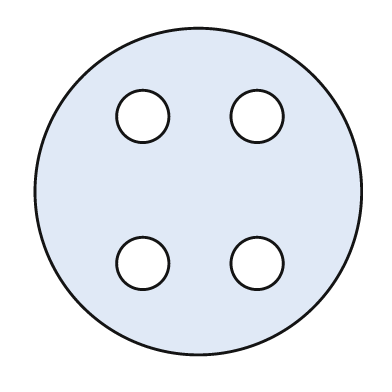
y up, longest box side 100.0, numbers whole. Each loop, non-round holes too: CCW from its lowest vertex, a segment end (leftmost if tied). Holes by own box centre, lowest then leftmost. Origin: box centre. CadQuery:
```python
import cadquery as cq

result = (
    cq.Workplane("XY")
    .moveTo(0.0, 0.0)
    .circle(50.0)
    .moveTo(-17.0, -22.0)
    .circle(8.0)
    .moveTo(18.0, -22.0)
    .circle(8.0)
    .moveTo(-17.0, 23.0)
    .circle(8.0)
    .moveTo(18.0, 23.0)
    .circle(8.0)
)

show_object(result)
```